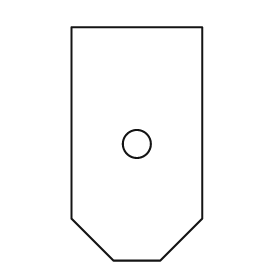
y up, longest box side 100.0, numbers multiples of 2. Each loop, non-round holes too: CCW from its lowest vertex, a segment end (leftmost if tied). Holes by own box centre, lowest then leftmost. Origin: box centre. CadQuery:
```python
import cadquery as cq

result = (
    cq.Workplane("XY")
    .moveTo(-10.0, -50.0)
    .lineTo(10.0, -50.0)
    .lineTo(28.0, -32.0)
    .lineTo(28.0, 50.0)
    .lineTo(-28.0, 50.0)
    .lineTo(-28.0, -32.0)
    .close()
    .moveTo(0.0, 0.0)
    .circle(6.0)
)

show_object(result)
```